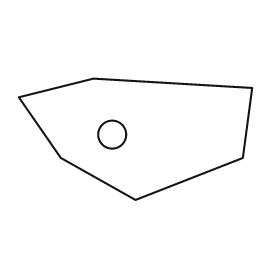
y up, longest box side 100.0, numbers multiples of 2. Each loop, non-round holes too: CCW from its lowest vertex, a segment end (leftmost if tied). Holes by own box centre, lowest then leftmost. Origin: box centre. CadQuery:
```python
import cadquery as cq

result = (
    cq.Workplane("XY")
    .moveTo(0.0, -26.0)
    .lineTo(46.0, -8.0)
    .lineTo(50.0, 22.0)
    .lineTo(-18.0, 26.0)
    .lineTo(-50.0, 18.0)
    .lineTo(-32.0, -8.0)
    .close()
    .moveTo(-10.0, 2.0)
    .circle(6.0)
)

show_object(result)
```